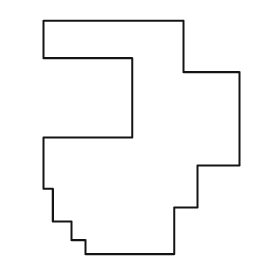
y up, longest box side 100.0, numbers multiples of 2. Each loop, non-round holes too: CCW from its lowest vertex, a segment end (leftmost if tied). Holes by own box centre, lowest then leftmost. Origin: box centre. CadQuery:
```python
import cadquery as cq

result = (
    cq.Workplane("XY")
    .moveTo(-24.0, -50.0)
    .lineTo(14.0, -50.0)
    .lineTo(14.0, -30.0)
    .lineTo(24.0, -30.0)
    .lineTo(24.0, -12.0)
    .lineTo(42.0, -12.0)
    .lineTo(42.0, 28.0)
    .lineTo(18.0, 28.0)
    .lineTo(18.0, 50.0)
    .lineTo(-42.0, 50.0)
    .lineTo(-42.0, 34.0)
    .lineTo(-4.0, 34.0)
    .lineTo(-4.0, 0.0)
    .lineTo(-42.0, 0.0)
    .lineTo(-42.0, -22.0)
    .lineTo(-38.0, -22.0)
    .lineTo(-38.0, -36.0)
    .lineTo(-30.0, -36.0)
    .lineTo(-30.0, -44.0)
    .lineTo(-24.0, -44.0)
    .close()
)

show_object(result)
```